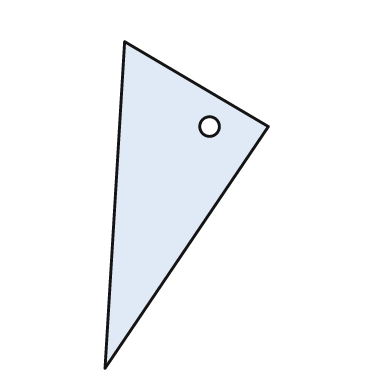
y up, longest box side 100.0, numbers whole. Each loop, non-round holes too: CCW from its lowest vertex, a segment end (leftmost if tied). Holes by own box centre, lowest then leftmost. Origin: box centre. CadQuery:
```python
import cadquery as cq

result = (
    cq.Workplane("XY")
    .moveTo(-25.0, -50.0)
    .lineTo(25.0, 24.0)
    .lineTo(-19.0, 50.0)
    .close()
    .moveTo(7.0, 24.0)
    .circle(3.0)
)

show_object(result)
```